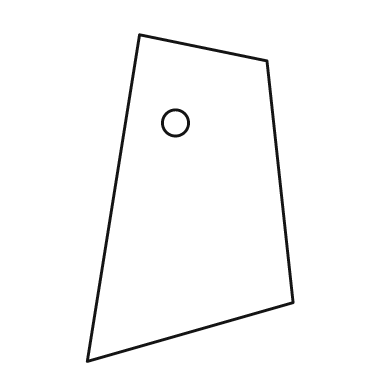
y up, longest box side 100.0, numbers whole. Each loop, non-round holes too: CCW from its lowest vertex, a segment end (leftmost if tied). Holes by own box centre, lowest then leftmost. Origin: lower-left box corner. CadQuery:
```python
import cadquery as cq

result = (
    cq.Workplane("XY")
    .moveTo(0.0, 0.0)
    .lineTo(63.0, 18.0)
    .lineTo(55.0, 92.0)
    .lineTo(16.0, 100.0)
    .close()
    .moveTo(27.0, 73.0)
    .circle(4.0)
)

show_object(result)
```